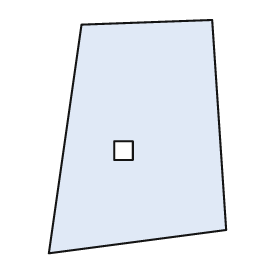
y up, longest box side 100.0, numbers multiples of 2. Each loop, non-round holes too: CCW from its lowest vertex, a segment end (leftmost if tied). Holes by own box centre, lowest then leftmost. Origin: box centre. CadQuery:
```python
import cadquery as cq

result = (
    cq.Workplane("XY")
    .moveTo(-38.0, -50.0)
    .lineTo(38.0, -40.0)
    .lineTo(32.0, 50.0)
    .lineTo(-24.0, 48.0)
    .close()
    .moveTo(-10.0, -10.0)
    .lineTo(-2.0, -10.0)
    .lineTo(-2.0, -2.0)
    .lineTo(-10.0, -2.0)
    .close()
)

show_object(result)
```